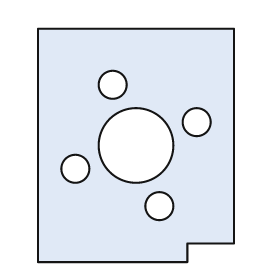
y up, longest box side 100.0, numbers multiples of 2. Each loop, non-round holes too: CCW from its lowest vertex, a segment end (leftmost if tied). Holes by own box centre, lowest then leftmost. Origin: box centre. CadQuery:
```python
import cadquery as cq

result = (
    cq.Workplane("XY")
    .moveTo(-42.0, -50.0)
    .lineTo(22.0, -50.0)
    .lineTo(22.0, -42.0)
    .lineTo(42.0, -42.0)
    .lineTo(42.0, 50.0)
    .lineTo(-42.0, 50.0)
    .close()
    .moveTo(10.0, -26.0)
    .circle(6.0)
    .moveTo(-26.0, -10.0)
    .circle(6.0)
    .moveTo(0.0, 0.0)
    .circle(16.0)
    .moveTo(26.0, 10.0)
    .circle(6.0)
    .moveTo(-10.0, 26.0)
    .circle(6.0)
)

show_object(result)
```